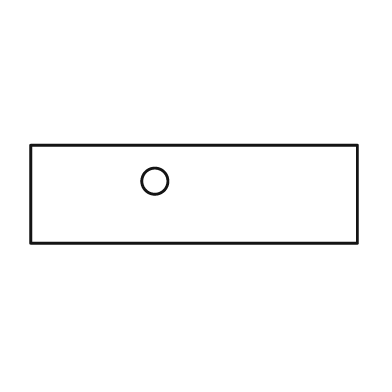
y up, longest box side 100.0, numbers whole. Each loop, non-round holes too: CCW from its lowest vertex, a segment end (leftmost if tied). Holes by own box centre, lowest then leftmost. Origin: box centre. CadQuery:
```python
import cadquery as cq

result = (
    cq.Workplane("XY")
    .moveTo(-50.0, -15.0)
    .lineTo(50.0, -15.0)
    .lineTo(50.0, 15.0)
    .lineTo(-50.0, 15.0)
    .close()
    .moveTo(-12.0, 4.0)
    .circle(4.0)
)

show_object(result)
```